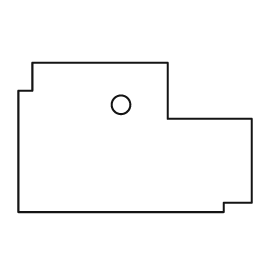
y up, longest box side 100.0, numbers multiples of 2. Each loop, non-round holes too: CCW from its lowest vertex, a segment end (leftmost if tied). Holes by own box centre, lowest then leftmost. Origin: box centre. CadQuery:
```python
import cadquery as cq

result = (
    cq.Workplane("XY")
    .moveTo(-50.0, -32.0)
    .lineTo(38.0, -32.0)
    .lineTo(38.0, -28.0)
    .lineTo(50.0, -28.0)
    .lineTo(50.0, 8.0)
    .lineTo(14.0, 8.0)
    .lineTo(14.0, 32.0)
    .lineTo(-44.0, 32.0)
    .lineTo(-44.0, 20.0)
    .lineTo(-50.0, 20.0)
    .close()
    .moveTo(-6.0, 14.0)
    .circle(4.0)
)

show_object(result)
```